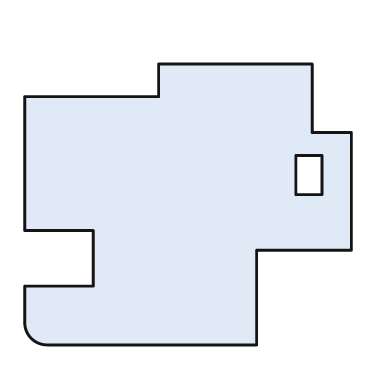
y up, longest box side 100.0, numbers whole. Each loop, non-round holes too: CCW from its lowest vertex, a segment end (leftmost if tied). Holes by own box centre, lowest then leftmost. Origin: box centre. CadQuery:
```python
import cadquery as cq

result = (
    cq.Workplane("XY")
    .moveTo(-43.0, -43.0)
    .lineTo(21.0, -43.0)
    .lineTo(21.0, -14.0)
    .lineTo(50.0, -14.0)
    .lineTo(50.0, 22.0)
    .lineTo(38.0, 22.0)
    .lineTo(38.0, 43.0)
    .lineTo(-9.0, 43.0)
    .lineTo(-9.0, 33.0)
    .lineTo(-50.0, 33.0)
    .lineTo(-50.0, -8.0)
    .lineTo(-29.0, -8.0)
    .lineTo(-29.0, -25.0)
    .lineTo(-50.0, -25.0)
    .lineTo(-50.0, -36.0)
    .threePointArc((-48.0, -41.0), (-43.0, -43.0))
    .close()
    .moveTo(33.0, 3.0)
    .lineTo(41.0, 3.0)
    .lineTo(41.0, 15.0)
    .lineTo(33.0, 15.0)
    .close()
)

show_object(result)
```